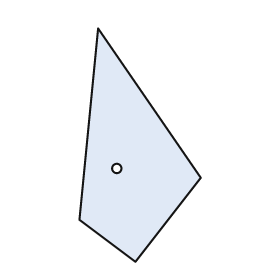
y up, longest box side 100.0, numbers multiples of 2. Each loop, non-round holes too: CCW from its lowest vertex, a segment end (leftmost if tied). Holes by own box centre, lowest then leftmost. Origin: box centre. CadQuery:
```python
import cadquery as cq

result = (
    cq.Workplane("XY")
    .moveTo(-2.0, -50.0)
    .lineTo(26.0, -14.0)
    .lineTo(-18.0, 50.0)
    .lineTo(-26.0, -32.0)
    .close()
    .moveTo(-10.0, -10.0)
    .circle(2.0)
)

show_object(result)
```